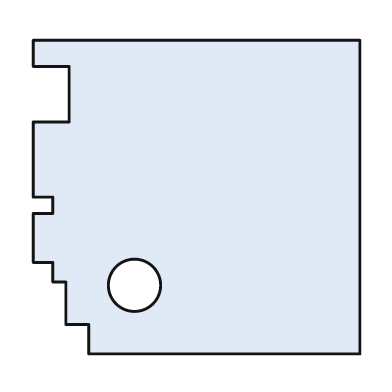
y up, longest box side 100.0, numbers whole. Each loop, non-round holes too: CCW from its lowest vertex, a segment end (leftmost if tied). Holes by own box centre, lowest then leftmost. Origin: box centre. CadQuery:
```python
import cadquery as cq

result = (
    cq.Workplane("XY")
    .moveTo(-33.0, -48.0)
    .lineTo(50.0, -48.0)
    .lineTo(50.0, 48.0)
    .lineTo(-50.0, 48.0)
    .lineTo(-50.0, 40.0)
    .lineTo(-39.0, 40.0)
    .lineTo(-39.0, 23.0)
    .lineTo(-50.0, 23.0)
    .lineTo(-50.0, 0.0)
    .lineTo(-44.0, 0.0)
    .lineTo(-44.0, -5.0)
    .lineTo(-50.0, -5.0)
    .lineTo(-50.0, -20.0)
    .lineTo(-44.0, -20.0)
    .lineTo(-44.0, -26.0)
    .lineTo(-40.0, -26.0)
    .lineTo(-40.0, -39.0)
    .lineTo(-33.0, -39.0)
    .close()
    .moveTo(-19.0, -27.0)
    .circle(8.0)
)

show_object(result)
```